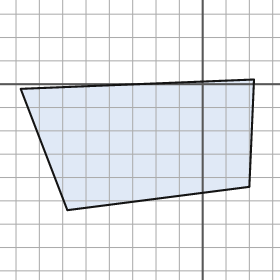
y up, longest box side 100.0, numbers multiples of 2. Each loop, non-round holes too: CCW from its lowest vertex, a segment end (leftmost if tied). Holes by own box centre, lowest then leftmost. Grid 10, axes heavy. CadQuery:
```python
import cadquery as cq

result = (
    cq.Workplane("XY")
    .moveTo(-58.0, -54.0)
    .lineTo(20.0, -44.0)
    .lineTo(22.0, 2.0)
    .lineTo(-78.0, -2.0)
    .close()
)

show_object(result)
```